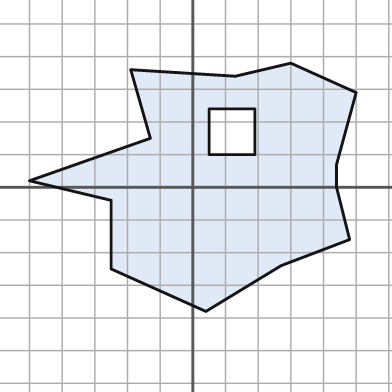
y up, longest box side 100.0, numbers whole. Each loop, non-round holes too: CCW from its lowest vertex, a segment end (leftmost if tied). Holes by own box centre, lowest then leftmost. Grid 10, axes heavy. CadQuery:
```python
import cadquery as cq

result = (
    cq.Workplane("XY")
    .moveTo(4.0, -38.0)
    .lineTo(27.0, -24.0)
    .lineTo(48.0, -16.0)
    .lineTo(44.0, 0.0)
    .lineTo(44.0, 7.0)
    .lineTo(50.0, 29.0)
    .lineTo(30.0, 38.0)
    .lineTo(13.0, 34.0)
    .lineTo(-19.0, 36.0)
    .lineTo(-13.0, 15.0)
    .lineTo(-50.0, 2.0)
    .lineTo(-25.0, -4.0)
    .lineTo(-25.0, -25.0)
    .close()
    .moveTo(5.0, 10.0)
    .lineTo(19.0, 10.0)
    .lineTo(19.0, 24.0)
    .lineTo(5.0, 24.0)
    .close()
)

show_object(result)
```